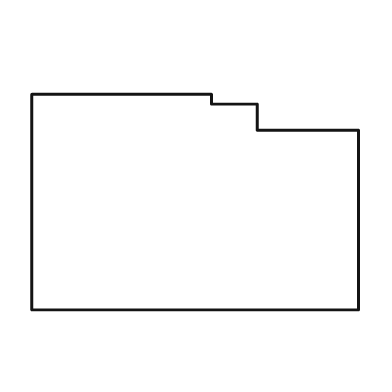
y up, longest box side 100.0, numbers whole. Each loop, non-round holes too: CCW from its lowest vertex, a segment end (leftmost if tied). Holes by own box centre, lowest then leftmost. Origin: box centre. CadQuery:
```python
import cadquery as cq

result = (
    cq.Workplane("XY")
    .moveTo(-50.0, -33.0)
    .lineTo(50.0, -33.0)
    .lineTo(50.0, 22.0)
    .lineTo(19.0, 22.0)
    .lineTo(19.0, 30.0)
    .lineTo(5.0, 30.0)
    .lineTo(5.0, 33.0)
    .lineTo(-50.0, 33.0)
    .close()
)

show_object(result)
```